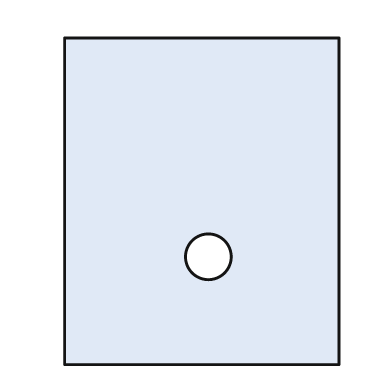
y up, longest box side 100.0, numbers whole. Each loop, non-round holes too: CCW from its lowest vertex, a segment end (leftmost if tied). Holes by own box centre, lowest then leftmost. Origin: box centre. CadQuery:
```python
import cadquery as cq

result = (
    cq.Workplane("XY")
    .moveTo(-42.0, -50.0)
    .lineTo(42.0, -50.0)
    .lineTo(42.0, 50.0)
    .lineTo(-42.0, 50.0)
    .close()
    .moveTo(2.0, -17.0)
    .circle(7.0)
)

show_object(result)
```